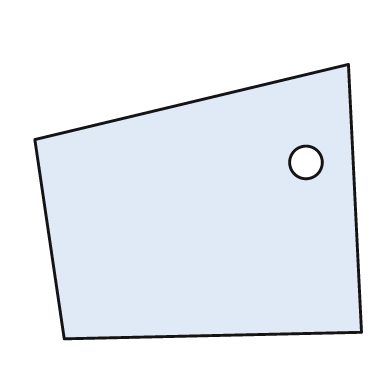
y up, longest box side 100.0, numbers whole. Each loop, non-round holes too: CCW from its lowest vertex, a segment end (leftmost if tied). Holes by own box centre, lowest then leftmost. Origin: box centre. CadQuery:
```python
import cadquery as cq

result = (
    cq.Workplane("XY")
    .moveTo(-41.0, -42.0)
    .lineTo(50.0, -40.0)
    .lineTo(46.0, 42.0)
    .lineTo(-50.0, 19.0)
    .close()
    .moveTo(33.0, 12.0)
    .circle(5.0)
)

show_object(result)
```